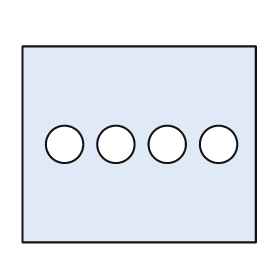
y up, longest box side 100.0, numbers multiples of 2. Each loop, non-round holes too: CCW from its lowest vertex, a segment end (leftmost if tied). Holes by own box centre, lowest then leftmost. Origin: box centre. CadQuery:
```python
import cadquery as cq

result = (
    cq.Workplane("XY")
    .moveTo(-50.0, -42.0)
    .lineTo(50.0, -42.0)
    .lineTo(50.0, 42.0)
    .lineTo(-50.0, 42.0)
    .close()
    .moveTo(-32.0, 0.0)
    .circle(8.0)
    .moveTo(-10.0, 0.0)
    .circle(8.0)
    .moveTo(12.0, 0.0)
    .circle(8.0)
    .moveTo(34.0, 0.0)
    .circle(8.0)
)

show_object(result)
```